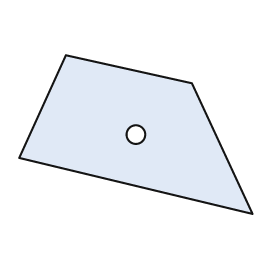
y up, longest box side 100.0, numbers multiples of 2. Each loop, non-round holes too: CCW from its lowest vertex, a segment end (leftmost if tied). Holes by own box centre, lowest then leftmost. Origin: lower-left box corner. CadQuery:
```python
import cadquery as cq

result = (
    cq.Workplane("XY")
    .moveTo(100.0, 0.0)
    .lineTo(74.0, 56.0)
    .lineTo(20.0, 68.0)
    .lineTo(0.0, 24.0)
    .close()
    .moveTo(50.0, 34.0)
    .circle(4.0)
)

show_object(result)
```